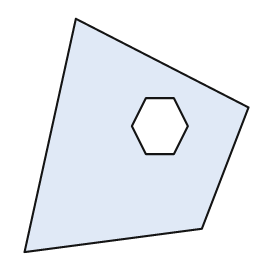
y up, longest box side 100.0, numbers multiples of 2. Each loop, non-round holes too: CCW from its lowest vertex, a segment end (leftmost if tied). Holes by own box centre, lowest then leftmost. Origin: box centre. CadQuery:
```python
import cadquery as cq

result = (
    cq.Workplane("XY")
    .moveTo(-48.0, -50.0)
    .lineTo(28.0, -40.0)
    .lineTo(48.0, 12.0)
    .lineTo(-26.0, 50.0)
    .close()
    .moveTo(4.0, -8.0)
    .lineTo(16.0, -8.0)
    .lineTo(22.0, 4.0)
    .lineTo(16.0, 16.0)
    .lineTo(4.0, 16.0)
    .lineTo(-2.0, 4.0)
    .close()
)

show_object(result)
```